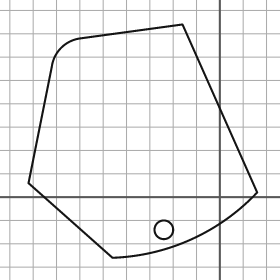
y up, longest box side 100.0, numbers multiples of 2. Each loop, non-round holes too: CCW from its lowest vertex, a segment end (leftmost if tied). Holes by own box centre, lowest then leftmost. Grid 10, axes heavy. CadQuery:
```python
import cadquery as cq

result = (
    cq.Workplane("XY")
    .moveTo(-46.0, -26.0)
    .threePointArc((-12.0, -18.0), (16.0, 2.0))
    .lineTo(-16.0, 74.0)
    .lineTo(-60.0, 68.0)
    .threePointArc((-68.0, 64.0), (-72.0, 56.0))
    .lineTo(-82.0, 6.0)
    .close()
    .moveTo(-24.0, -14.0)
    .circle(4.0)
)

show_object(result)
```